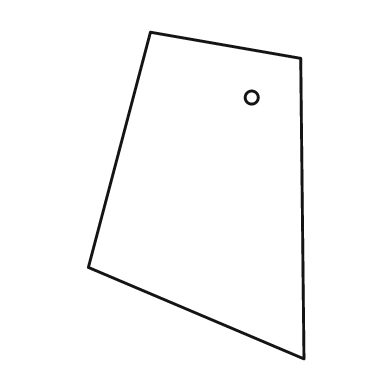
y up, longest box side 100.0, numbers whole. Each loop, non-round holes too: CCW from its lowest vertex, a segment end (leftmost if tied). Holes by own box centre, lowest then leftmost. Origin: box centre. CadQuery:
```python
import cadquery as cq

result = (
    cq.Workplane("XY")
    .moveTo(33.0, -50.0)
    .lineTo(32.0, 42.0)
    .lineTo(-14.0, 50.0)
    .lineTo(-33.0, -22.0)
    .close()
    .moveTo(17.0, 30.0)
    .circle(2.0)
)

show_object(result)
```